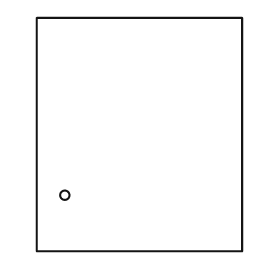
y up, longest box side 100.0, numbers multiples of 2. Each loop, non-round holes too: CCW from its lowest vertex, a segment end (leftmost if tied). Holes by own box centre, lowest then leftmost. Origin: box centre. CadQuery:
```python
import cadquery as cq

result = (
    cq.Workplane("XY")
    .moveTo(-44.0, -50.0)
    .lineTo(44.0, -50.0)
    .lineTo(44.0, 50.0)
    .lineTo(-44.0, 50.0)
    .close()
    .moveTo(-32.0, -26.0)
    .circle(2.0)
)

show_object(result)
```